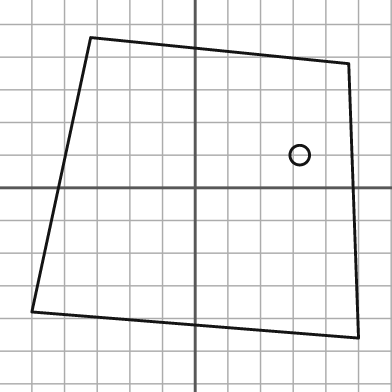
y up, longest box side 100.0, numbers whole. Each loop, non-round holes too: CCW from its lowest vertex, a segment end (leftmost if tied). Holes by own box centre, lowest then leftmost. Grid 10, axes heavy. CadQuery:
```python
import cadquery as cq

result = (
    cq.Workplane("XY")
    .moveTo(50.0, -46.0)
    .lineTo(47.0, 38.0)
    .lineTo(-32.0, 46.0)
    .lineTo(-50.0, -38.0)
    .close()
    .moveTo(32.0, 10.0)
    .circle(3.0)
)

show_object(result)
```